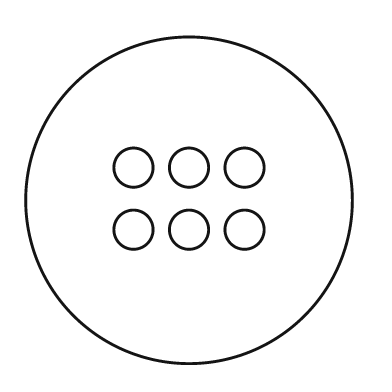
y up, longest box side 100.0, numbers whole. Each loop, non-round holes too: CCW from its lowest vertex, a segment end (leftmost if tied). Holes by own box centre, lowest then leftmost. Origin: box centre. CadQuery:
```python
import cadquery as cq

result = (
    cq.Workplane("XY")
    .moveTo(0.0, 0.0)
    .circle(50.0)
    .moveTo(-17.0, -9.0)
    .circle(6.0)
    .moveTo(0.0, -9.0)
    .circle(6.0)
    .moveTo(17.0, -9.0)
    .circle(6.0)
    .moveTo(-17.0, 10.0)
    .circle(6.0)
    .moveTo(0.0, 10.0)
    .circle(6.0)
    .moveTo(17.0, 10.0)
    .circle(6.0)
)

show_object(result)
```